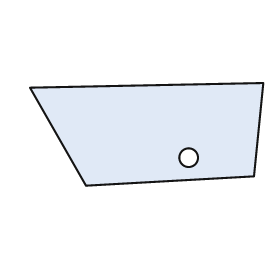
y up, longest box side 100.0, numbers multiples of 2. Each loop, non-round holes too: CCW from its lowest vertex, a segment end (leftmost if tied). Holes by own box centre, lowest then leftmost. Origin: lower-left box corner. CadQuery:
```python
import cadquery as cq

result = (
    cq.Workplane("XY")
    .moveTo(24.0, 0.0)
    .lineTo(96.0, 4.0)
    .lineTo(100.0, 44.0)
    .lineTo(0.0, 42.0)
    .close()
    .moveTo(68.0, 12.0)
    .circle(4.0)
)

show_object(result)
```